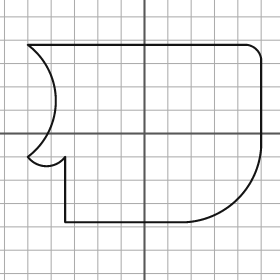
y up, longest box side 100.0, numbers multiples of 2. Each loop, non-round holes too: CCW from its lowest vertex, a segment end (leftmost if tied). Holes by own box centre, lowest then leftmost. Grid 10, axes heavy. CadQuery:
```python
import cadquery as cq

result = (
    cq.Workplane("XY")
    .moveTo(-34.0, -38.0)
    .lineTo(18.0, -38.0)
    .threePointArc((40.0, -28.0), (50.0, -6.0))
    .lineTo(50.0, 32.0)
    .threePointArc((48.0, 36.0), (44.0, 38.0))
    .lineTo(-50.0, 38.0)
    .threePointArc((-38.0, 14.0), (-50.0, -10.0))
    .threePointArc((-42.0, -14.0), (-34.0, -10.0))
    .close()
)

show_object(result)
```